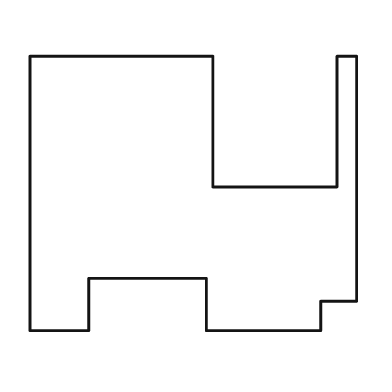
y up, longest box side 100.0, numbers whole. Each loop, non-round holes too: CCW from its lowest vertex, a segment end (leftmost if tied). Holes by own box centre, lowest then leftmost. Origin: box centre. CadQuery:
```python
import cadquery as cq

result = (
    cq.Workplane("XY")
    .moveTo(-50.0, -42.0)
    .lineTo(-32.0, -42.0)
    .lineTo(-32.0, -26.0)
    .lineTo(4.0, -26.0)
    .lineTo(4.0, -42.0)
    .lineTo(39.0, -42.0)
    .lineTo(39.0, -33.0)
    .lineTo(50.0, -33.0)
    .lineTo(50.0, 42.0)
    .lineTo(44.0, 42.0)
    .lineTo(44.0, 2.0)
    .lineTo(6.0, 2.0)
    .lineTo(6.0, 42.0)
    .lineTo(-50.0, 42.0)
    .close()
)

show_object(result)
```